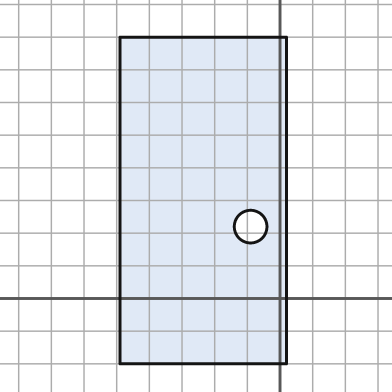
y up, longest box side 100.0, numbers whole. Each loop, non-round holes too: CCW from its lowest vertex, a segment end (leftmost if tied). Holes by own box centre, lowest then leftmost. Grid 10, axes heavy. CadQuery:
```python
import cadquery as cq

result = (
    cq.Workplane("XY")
    .moveTo(-49.0, -20.0)
    .lineTo(2.0, -20.0)
    .lineTo(2.0, 80.0)
    .lineTo(-49.0, 80.0)
    .close()
    .moveTo(-9.0, 22.0)
    .circle(5.0)
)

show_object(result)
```